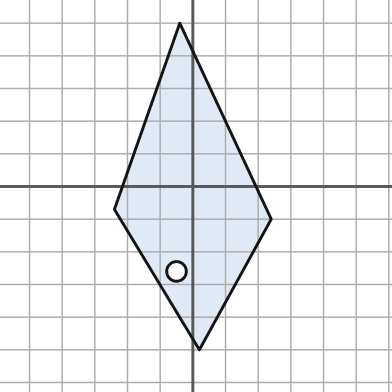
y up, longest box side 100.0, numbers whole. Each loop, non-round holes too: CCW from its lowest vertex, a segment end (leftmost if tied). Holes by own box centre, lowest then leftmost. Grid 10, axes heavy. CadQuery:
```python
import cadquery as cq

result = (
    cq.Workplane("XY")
    .moveTo(2.0, -50.0)
    .lineTo(24.0, -10.0)
    .lineTo(-4.0, 50.0)
    .lineTo(-24.0, -7.0)
    .close()
    .moveTo(-5.0, -26.0)
    .circle(3.0)
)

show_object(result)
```